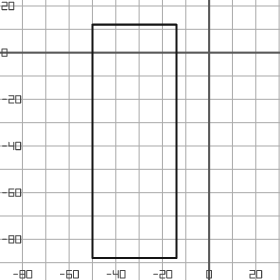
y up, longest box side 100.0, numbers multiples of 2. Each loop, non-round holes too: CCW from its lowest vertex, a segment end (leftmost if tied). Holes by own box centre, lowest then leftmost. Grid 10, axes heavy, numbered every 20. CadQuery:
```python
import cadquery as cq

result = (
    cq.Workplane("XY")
    .moveTo(-50.0, -88.0)
    .lineTo(-14.0, -88.0)
    .lineTo(-14.0, 12.0)
    .lineTo(-50.0, 12.0)
    .close()
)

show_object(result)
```